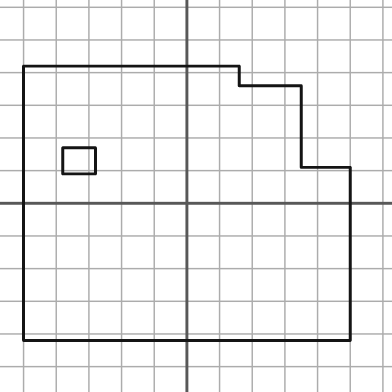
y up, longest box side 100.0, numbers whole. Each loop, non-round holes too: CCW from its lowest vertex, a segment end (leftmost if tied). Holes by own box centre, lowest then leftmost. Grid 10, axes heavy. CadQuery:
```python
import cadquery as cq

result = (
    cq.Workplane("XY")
    .moveTo(-50.0, -42.0)
    .lineTo(50.0, -42.0)
    .lineTo(50.0, 11.0)
    .lineTo(35.0, 11.0)
    .lineTo(35.0, 36.0)
    .lineTo(16.0, 36.0)
    .lineTo(16.0, 42.0)
    .lineTo(-50.0, 42.0)
    .close()
    .moveTo(-38.0, 9.0)
    .lineTo(-28.0, 9.0)
    .lineTo(-28.0, 17.0)
    .lineTo(-38.0, 17.0)
    .close()
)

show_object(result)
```